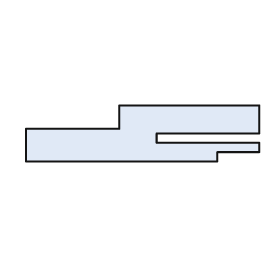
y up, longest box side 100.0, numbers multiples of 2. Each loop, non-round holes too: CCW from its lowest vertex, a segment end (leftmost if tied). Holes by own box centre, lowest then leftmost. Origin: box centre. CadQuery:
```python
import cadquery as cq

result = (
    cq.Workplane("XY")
    .moveTo(-50.0, -12.0)
    .lineTo(32.0, -12.0)
    .lineTo(32.0, -8.0)
    .lineTo(50.0, -8.0)
    .lineTo(50.0, -4.0)
    .lineTo(6.0, -4.0)
    .lineTo(6.0, 0.0)
    .lineTo(50.0, 0.0)
    .lineTo(50.0, 12.0)
    .lineTo(-10.0, 12.0)
    .lineTo(-10.0, 2.0)
    .lineTo(-50.0, 2.0)
    .close()
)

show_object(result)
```